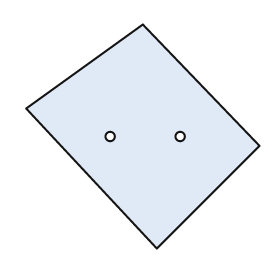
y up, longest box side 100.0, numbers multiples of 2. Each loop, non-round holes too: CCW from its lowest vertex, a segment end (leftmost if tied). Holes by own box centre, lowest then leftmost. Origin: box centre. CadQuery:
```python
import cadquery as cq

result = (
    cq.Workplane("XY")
    .moveTo(6.0, -48.0)
    .lineTo(50.0, -4.0)
    .lineTo(0.0, 48.0)
    .lineTo(-50.0, 12.0)
    .close()
    .moveTo(-14.0, 0.0)
    .circle(2.0)
    .moveTo(16.0, 0.0)
    .circle(2.0)
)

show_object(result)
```